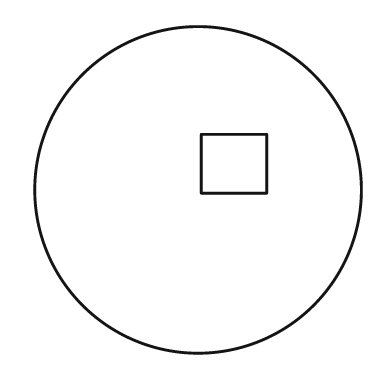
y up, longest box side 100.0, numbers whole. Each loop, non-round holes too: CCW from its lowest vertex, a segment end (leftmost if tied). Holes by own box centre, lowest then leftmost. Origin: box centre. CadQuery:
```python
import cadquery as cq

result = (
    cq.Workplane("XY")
    .moveTo(0.0, 0.0)
    .circle(50.0)
    .moveTo(1.0, -1.0)
    .lineTo(21.0, -1.0)
    .lineTo(21.0, 17.0)
    .lineTo(1.0, 17.0)
    .close()
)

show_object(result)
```